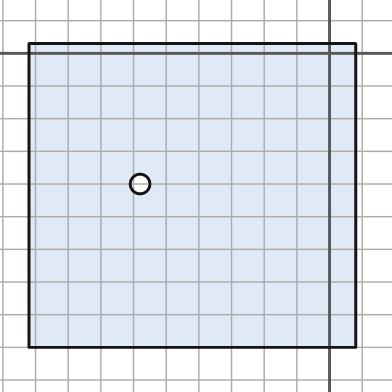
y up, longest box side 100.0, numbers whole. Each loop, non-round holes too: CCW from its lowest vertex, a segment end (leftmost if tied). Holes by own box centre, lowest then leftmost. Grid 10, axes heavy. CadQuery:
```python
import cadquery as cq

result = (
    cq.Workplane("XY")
    .moveTo(-92.0, -90.0)
    .lineTo(8.0, -90.0)
    .lineTo(8.0, 3.0)
    .lineTo(-92.0, 3.0)
    .close()
    .moveTo(-58.0, -40.0)
    .circle(3.0)
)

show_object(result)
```